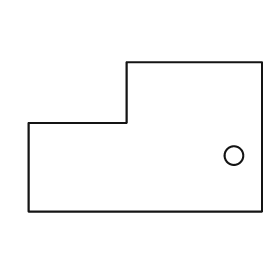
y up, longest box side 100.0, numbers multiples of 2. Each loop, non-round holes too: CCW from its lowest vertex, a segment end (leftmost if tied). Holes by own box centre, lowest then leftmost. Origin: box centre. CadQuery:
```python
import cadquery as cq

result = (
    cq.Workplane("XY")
    .moveTo(-50.0, -32.0)
    .lineTo(50.0, -32.0)
    .lineTo(50.0, 32.0)
    .lineTo(-8.0, 32.0)
    .lineTo(-8.0, 6.0)
    .lineTo(-50.0, 6.0)
    .close()
    .moveTo(38.0, -8.0)
    .circle(4.0)
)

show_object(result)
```